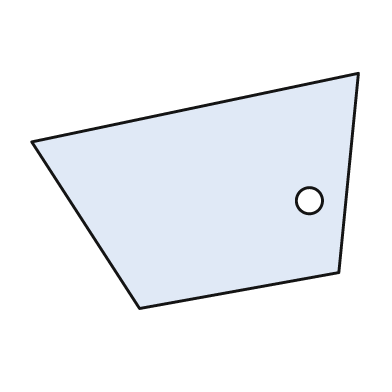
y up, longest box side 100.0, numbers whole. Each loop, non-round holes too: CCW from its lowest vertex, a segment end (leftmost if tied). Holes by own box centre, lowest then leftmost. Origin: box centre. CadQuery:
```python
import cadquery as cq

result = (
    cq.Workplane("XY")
    .moveTo(-17.0, -36.0)
    .lineTo(44.0, -25.0)
    .lineTo(50.0, 36.0)
    .lineTo(-50.0, 15.0)
    .close()
    .moveTo(35.0, -3.0)
    .circle(4.0)
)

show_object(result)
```